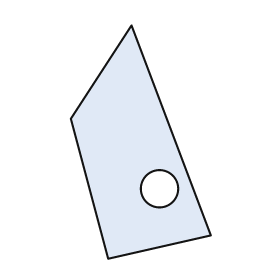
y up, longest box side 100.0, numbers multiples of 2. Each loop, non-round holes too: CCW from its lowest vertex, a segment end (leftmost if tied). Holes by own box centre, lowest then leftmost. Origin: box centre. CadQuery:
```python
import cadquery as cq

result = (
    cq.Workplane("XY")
    .moveTo(-14.0, -50.0)
    .lineTo(30.0, -40.0)
    .lineTo(-4.0, 50.0)
    .lineTo(-30.0, 10.0)
    .close()
    .moveTo(8.0, -20.0)
    .circle(8.0)
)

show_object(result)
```